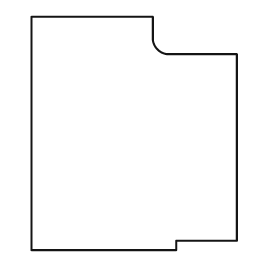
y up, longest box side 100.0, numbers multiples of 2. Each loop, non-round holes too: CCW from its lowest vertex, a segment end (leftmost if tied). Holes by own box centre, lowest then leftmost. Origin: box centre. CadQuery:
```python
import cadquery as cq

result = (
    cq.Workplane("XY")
    .moveTo(-44.0, -50.0)
    .lineTo(18.0, -50.0)
    .lineTo(18.0, -46.0)
    .lineTo(44.0, -46.0)
    .lineTo(44.0, 34.0)
    .lineTo(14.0, 34.0)
    .threePointArc((10.0, 36.0), (8.0, 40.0))
    .lineTo(8.0, 50.0)
    .lineTo(-44.0, 50.0)
    .close()
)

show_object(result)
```